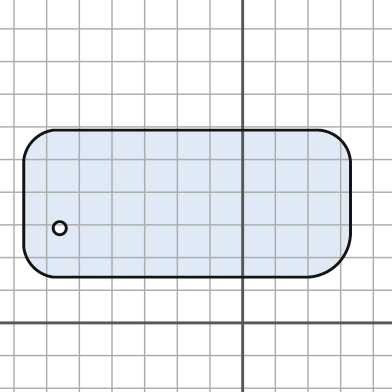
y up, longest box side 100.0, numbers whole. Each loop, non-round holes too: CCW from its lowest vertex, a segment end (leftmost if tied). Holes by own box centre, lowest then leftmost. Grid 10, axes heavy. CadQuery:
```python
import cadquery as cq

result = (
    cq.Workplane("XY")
    .moveTo(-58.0, 14.0)
    .lineTo(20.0, 14.0)
    .threePointArc((29.0, 18.0), (33.0, 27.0))
    .lineTo(33.0, 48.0)
    .threePointArc((30.0, 56.0), (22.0, 59.0))
    .lineTo(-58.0, 59.0)
    .threePointArc((-64.0, 56.0), (-67.0, 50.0))
    .lineTo(-67.0, 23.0)
    .threePointArc((-64.0, 17.0), (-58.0, 14.0))
    .close()
    .moveTo(-56.0, 29.0)
    .circle(2.0)
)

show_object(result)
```